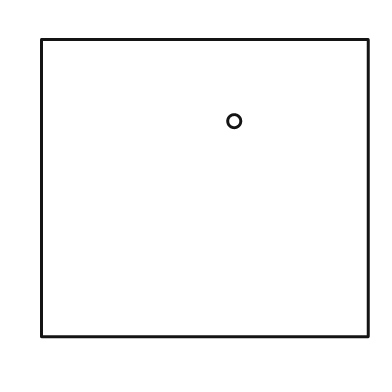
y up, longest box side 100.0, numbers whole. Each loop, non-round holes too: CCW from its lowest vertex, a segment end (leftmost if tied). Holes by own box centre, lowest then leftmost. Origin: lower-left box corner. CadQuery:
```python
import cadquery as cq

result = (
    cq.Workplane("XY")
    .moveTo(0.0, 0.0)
    .lineTo(100.0, 0.0)
    .lineTo(100.0, 91.0)
    .lineTo(0.0, 91.0)
    .close()
    .moveTo(59.0, 66.0)
    .circle(2.0)
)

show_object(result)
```